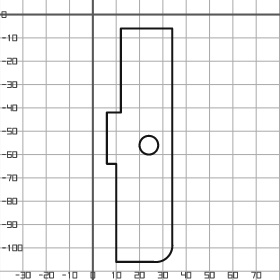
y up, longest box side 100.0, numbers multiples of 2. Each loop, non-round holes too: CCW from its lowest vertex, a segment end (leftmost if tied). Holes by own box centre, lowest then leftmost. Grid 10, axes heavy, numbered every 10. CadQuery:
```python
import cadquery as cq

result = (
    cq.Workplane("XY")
    .moveTo(10.0, -106.0)
    .lineTo(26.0, -106.0)
    .threePointArc((32.0, -104.0), (34.0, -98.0))
    .lineTo(34.0, -6.0)
    .lineTo(12.0, -6.0)
    .lineTo(12.0, -42.0)
    .lineTo(6.0, -42.0)
    .lineTo(6.0, -64.0)
    .lineTo(10.0, -64.0)
    .close()
    .moveTo(24.0, -56.0)
    .circle(4.0)
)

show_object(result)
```